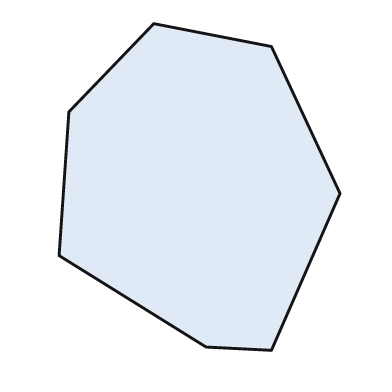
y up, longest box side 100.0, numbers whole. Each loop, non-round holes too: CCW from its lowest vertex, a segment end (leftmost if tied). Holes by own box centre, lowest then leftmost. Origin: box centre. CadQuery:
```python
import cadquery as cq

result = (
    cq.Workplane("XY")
    .moveTo(22.0, -50.0)
    .lineTo(43.0, -2.0)
    .lineTo(22.0, 43.0)
    .lineTo(-14.0, 50.0)
    .lineTo(-40.0, 23.0)
    .lineTo(-43.0, -21.0)
    .lineTo(2.0, -49.0)
    .close()
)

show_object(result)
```